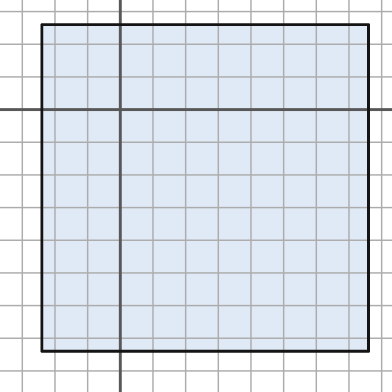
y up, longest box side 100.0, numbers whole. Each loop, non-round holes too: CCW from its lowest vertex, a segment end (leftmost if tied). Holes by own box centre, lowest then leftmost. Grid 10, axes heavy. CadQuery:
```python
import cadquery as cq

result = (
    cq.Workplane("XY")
    .moveTo(-24.0, -74.0)
    .lineTo(76.0, -74.0)
    .lineTo(76.0, 26.0)
    .lineTo(-24.0, 26.0)
    .close()
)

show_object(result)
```